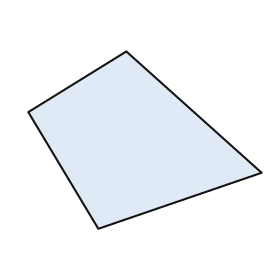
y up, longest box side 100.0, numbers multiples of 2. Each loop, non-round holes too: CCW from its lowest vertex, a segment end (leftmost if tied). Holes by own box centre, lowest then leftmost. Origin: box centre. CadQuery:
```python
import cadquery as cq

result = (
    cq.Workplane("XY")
    .moveTo(-20.0, -38.0)
    .lineTo(50.0, -14.0)
    .lineTo(-8.0, 38.0)
    .lineTo(-50.0, 12.0)
    .close()
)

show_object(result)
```